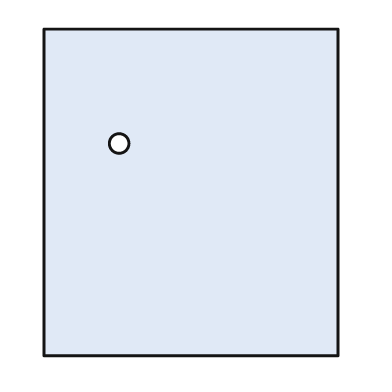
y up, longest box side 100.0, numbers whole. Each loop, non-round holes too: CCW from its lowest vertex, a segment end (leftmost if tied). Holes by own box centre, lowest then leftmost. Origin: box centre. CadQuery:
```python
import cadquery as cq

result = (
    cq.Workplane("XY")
    .moveTo(-45.0, -50.0)
    .lineTo(45.0, -50.0)
    .lineTo(45.0, 50.0)
    .lineTo(-45.0, 50.0)
    .close()
    .moveTo(-22.0, 15.0)
    .circle(3.0)
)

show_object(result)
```